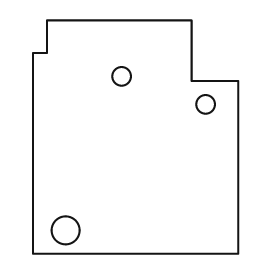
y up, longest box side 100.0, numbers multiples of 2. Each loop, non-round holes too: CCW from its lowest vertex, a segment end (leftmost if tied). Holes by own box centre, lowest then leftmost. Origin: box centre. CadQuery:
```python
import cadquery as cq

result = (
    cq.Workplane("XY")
    .moveTo(-44.0, -50.0)
    .lineTo(44.0, -50.0)
    .lineTo(44.0, 24.0)
    .lineTo(24.0, 24.0)
    .lineTo(24.0, 50.0)
    .lineTo(-38.0, 50.0)
    .lineTo(-38.0, 36.0)
    .lineTo(-44.0, 36.0)
    .close()
    .moveTo(-30.0, -40.0)
    .circle(6.0)
    .moveTo(30.0, 14.0)
    .circle(4.0)
    .moveTo(-6.0, 26.0)
    .circle(4.0)
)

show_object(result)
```